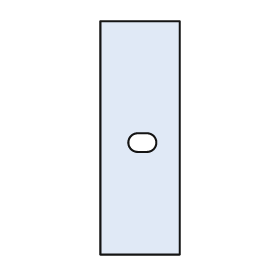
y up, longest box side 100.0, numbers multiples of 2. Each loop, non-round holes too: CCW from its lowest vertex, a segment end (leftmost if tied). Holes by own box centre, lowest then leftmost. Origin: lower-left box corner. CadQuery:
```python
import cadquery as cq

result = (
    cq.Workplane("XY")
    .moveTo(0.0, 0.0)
    .lineTo(34.0, 0.0)
    .lineTo(34.0, 100.0)
    .lineTo(0.0, 100.0)
    .close()
    .moveTo(16.0, 44.0)
    .lineTo(20.0, 44.0)
    .threePointArc((24.0, 48.0), (20.0, 52.0))
    .lineTo(16.0, 52.0)
    .threePointArc((12.0, 48.0), (16.0, 44.0))
    .close()
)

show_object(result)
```